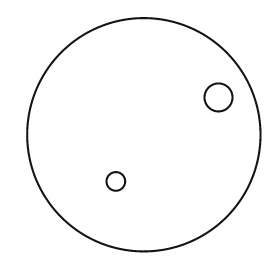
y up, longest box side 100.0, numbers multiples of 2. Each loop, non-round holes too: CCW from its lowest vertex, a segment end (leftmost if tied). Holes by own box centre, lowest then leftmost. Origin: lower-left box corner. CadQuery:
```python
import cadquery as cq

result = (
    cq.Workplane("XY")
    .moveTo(50.0, 50.0)
    .circle(50.0)
    .moveTo(38.0, 30.0)
    .circle(4.0)
    .moveTo(82.0, 66.0)
    .circle(6.0)
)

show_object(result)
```